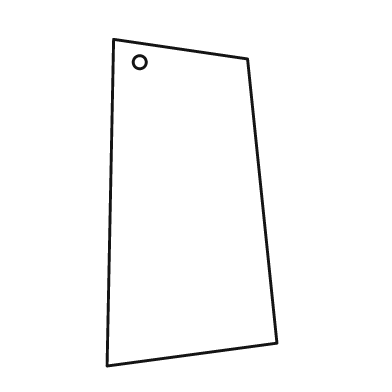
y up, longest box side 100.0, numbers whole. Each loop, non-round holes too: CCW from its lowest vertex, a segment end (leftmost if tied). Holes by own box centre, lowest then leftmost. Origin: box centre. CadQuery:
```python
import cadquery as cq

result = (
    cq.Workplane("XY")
    .moveTo(-26.0, -50.0)
    .lineTo(26.0, -43.0)
    .lineTo(17.0, 44.0)
    .lineTo(-24.0, 50.0)
    .close()
    .moveTo(-16.0, 43.0)
    .circle(2.0)
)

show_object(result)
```